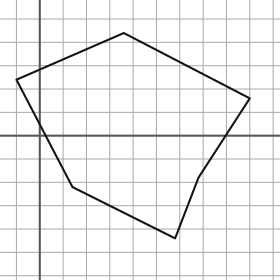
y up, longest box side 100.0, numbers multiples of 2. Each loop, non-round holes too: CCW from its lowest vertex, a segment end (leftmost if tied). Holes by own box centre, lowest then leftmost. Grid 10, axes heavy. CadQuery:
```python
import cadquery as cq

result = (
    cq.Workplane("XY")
    .moveTo(58.0, -44.0)
    .lineTo(68.0, -18.0)
    .lineTo(90.0, 16.0)
    .lineTo(36.0, 44.0)
    .lineTo(-10.0, 24.0)
    .lineTo(14.0, -22.0)
    .close()
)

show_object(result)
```